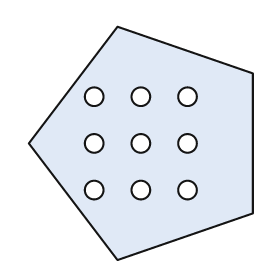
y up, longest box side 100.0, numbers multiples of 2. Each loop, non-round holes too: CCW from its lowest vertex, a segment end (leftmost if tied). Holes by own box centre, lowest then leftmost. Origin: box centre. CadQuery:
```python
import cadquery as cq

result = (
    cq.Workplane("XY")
    .moveTo(-10.0, -50.0)
    .lineTo(48.0, -30.0)
    .lineTo(48.0, 30.0)
    .lineTo(-10.0, 50.0)
    .lineTo(-48.0, 0.0)
    .close()
    .moveTo(-20.0, -20.0)
    .circle(4.0)
    .moveTo(0.0, -20.0)
    .circle(4.0)
    .moveTo(20.0, -20.0)
    .circle(4.0)
    .moveTo(-20.0, 0.0)
    .circle(4.0)
    .moveTo(0.0, 0.0)
    .circle(4.0)
    .moveTo(20.0, 0.0)
    .circle(4.0)
    .moveTo(-20.0, 20.0)
    .circle(4.0)
    .moveTo(0.0, 20.0)
    .circle(4.0)
    .moveTo(20.0, 20.0)
    .circle(4.0)
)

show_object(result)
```